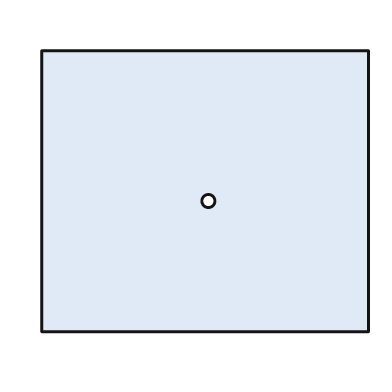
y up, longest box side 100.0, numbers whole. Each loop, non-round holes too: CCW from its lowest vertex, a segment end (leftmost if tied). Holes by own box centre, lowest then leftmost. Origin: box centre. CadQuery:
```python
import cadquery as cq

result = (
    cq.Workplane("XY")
    .moveTo(-50.0, -43.0)
    .lineTo(50.0, -43.0)
    .lineTo(50.0, 43.0)
    .lineTo(-50.0, 43.0)
    .close()
    .moveTo(1.0, -3.0)
    .circle(2.0)
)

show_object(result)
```